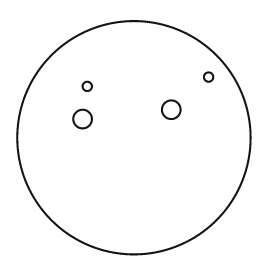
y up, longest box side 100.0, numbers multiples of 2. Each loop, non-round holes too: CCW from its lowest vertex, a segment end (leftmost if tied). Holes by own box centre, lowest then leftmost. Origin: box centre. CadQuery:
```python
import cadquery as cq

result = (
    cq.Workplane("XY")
    .moveTo(0.0, 0.0)
    .circle(50.0)
    .moveTo(-22.0, 8.0)
    .circle(4.0)
    .moveTo(16.0, 12.0)
    .circle(4.0)
    .moveTo(-20.0, 22.0)
    .circle(2.0)
    .moveTo(32.0, 26.0)
    .circle(2.0)
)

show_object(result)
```